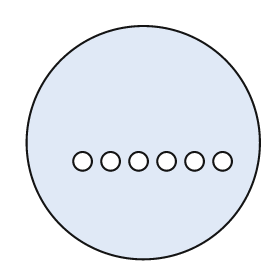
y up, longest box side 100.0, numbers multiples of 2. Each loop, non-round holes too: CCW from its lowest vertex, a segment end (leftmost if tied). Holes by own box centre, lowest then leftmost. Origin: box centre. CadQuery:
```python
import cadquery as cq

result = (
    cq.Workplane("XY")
    .moveTo(0.0, 0.0)
    .circle(50.0)
    .moveTo(-26.0, -8.0)
    .circle(4.0)
    .moveTo(-14.0, -8.0)
    .circle(4.0)
    .moveTo(-2.0, -8.0)
    .circle(4.0)
    .moveTo(10.0, -8.0)
    .circle(4.0)
    .moveTo(22.0, -8.0)
    .circle(4.0)
    .moveTo(34.0, -8.0)
    .circle(4.0)
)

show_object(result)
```